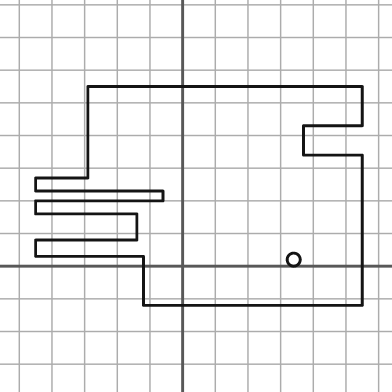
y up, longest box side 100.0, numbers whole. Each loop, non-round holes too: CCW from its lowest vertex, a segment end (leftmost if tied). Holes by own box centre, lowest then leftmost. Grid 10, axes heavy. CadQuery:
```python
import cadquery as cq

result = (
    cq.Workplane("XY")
    .moveTo(-12.0, -12.0)
    .lineTo(55.0, -12.0)
    .lineTo(55.0, 34.0)
    .lineTo(37.0, 34.0)
    .lineTo(37.0, 43.0)
    .lineTo(55.0, 43.0)
    .lineTo(55.0, 55.0)
    .lineTo(-29.0, 55.0)
    .lineTo(-29.0, 27.0)
    .lineTo(-45.0, 27.0)
    .lineTo(-45.0, 23.0)
    .lineTo(-6.0, 23.0)
    .lineTo(-6.0, 20.0)
    .lineTo(-45.0, 20.0)
    .lineTo(-45.0, 16.0)
    .lineTo(-14.0, 16.0)
    .lineTo(-14.0, 8.0)
    .lineTo(-45.0, 8.0)
    .lineTo(-45.0, 3.0)
    .lineTo(-12.0, 3.0)
    .close()
    .moveTo(34.0, 2.0)
    .circle(2.0)
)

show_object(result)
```